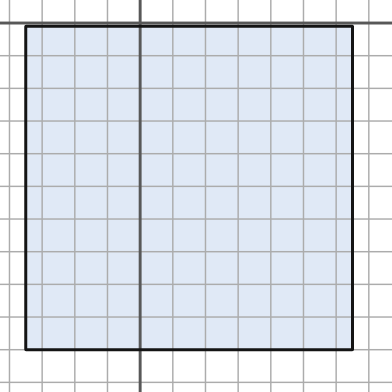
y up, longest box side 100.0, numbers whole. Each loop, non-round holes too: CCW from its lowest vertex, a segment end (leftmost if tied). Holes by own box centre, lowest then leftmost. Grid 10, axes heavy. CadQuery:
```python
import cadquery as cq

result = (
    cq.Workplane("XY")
    .moveTo(-35.0, -100.0)
    .lineTo(65.0, -100.0)
    .lineTo(65.0, -1.0)
    .lineTo(-35.0, -1.0)
    .close()
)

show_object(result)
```